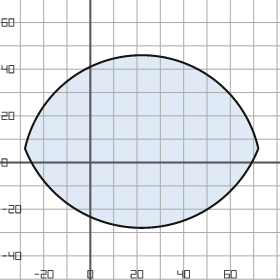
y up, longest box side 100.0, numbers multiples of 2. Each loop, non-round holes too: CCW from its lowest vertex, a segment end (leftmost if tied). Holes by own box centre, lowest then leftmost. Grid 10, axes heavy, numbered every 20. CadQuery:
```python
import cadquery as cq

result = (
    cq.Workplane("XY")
    .moveTo(-28.0, 6.0)
    .threePointArc((22.0, -28.0), (72.0, 6.0))
    .threePointArc((22.0, 46.0), (-28.0, 6.0))
    .close()
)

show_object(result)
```